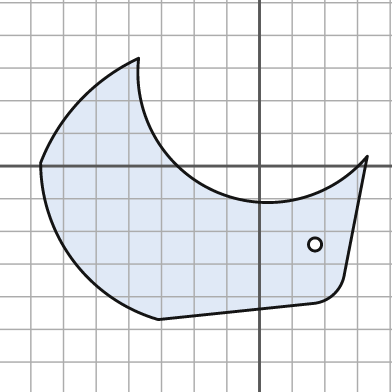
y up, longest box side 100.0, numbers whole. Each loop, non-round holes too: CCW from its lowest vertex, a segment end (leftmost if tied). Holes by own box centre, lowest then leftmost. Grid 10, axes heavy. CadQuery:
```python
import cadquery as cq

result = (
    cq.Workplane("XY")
    .moveTo(-31.0, -47.0)
    .lineTo(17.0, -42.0)
    .threePointArc((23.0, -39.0), (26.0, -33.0))
    .lineTo(33.0, 3.0)
    .threePointArc((-13.0, -8.0), (-37.0, 33.0))
    .threePointArc((-55.0, 20.0), (-67.0, 1.0))
    .threePointArc((-57.0, -29.0), (-31.0, -47.0))
    .close()
    .moveTo(17.0, -24.0)
    .circle(2.0)
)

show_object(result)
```